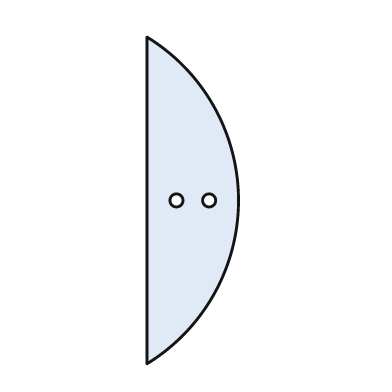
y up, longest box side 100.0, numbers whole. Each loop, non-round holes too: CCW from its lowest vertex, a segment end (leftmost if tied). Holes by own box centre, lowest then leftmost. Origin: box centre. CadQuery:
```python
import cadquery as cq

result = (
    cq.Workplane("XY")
    .moveTo(-14.0, -50.0)
    .threePointArc((14.0, 0.0), (-14.0, 50.0))
    .close()
    .moveTo(-5.0, 0.0)
    .circle(2.0)
    .moveTo(5.0, 0.0)
    .circle(2.0)
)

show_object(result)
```